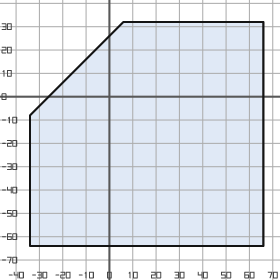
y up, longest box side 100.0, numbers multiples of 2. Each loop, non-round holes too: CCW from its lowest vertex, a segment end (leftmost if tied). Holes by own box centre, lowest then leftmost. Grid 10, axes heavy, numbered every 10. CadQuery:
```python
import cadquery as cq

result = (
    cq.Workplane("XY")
    .moveTo(-34.0, -64.0)
    .lineTo(66.0, -64.0)
    .lineTo(66.0, 32.0)
    .lineTo(6.0, 32.0)
    .lineTo(-34.0, -8.0)
    .close()
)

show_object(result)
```